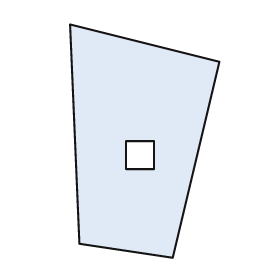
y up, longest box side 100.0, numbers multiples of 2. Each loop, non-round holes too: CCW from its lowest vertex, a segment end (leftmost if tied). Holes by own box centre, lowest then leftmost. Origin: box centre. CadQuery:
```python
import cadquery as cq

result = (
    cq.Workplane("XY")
    .moveTo(12.0, -50.0)
    .lineTo(32.0, 34.0)
    .lineTo(-32.0, 50.0)
    .lineTo(-28.0, -44.0)
    .close()
    .moveTo(-8.0, -12.0)
    .lineTo(4.0, -12.0)
    .lineTo(4.0, 0.0)
    .lineTo(-8.0, 0.0)
    .close()
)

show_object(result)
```